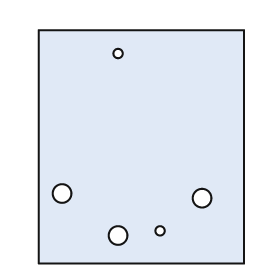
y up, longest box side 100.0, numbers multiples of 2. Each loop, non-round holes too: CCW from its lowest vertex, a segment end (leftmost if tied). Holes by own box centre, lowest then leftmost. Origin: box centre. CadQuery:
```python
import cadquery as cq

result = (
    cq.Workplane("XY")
    .moveTo(-44.0, -50.0)
    .lineTo(44.0, -50.0)
    .lineTo(44.0, 50.0)
    .lineTo(-44.0, 50.0)
    .close()
    .moveTo(-10.0, -38.0)
    .circle(4.0)
    .moveTo(8.0, -36.0)
    .circle(2.0)
    .moveTo(26.0, -22.0)
    .circle(4.0)
    .moveTo(-34.0, -20.0)
    .circle(4.0)
    .moveTo(-10.0, 40.0)
    .circle(2.0)
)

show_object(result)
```